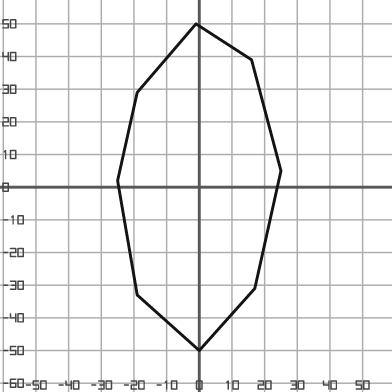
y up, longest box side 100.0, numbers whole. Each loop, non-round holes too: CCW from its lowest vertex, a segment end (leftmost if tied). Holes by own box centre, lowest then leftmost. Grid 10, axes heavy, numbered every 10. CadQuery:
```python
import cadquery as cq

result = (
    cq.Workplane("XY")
    .moveTo(0.0, -50.0)
    .lineTo(17.0, -31.0)
    .lineTo(25.0, 5.0)
    .lineTo(16.0, 39.0)
    .lineTo(-1.0, 50.0)
    .lineTo(-19.0, 29.0)
    .lineTo(-25.0, 2.0)
    .lineTo(-19.0, -33.0)
    .close()
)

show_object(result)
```